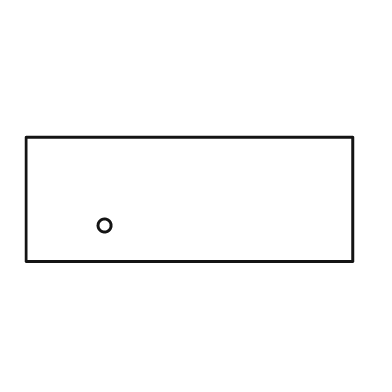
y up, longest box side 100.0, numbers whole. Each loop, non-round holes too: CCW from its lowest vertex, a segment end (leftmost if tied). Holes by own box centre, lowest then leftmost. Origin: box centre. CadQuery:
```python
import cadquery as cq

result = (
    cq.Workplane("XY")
    .moveTo(-50.0, -19.0)
    .lineTo(50.0, -19.0)
    .lineTo(50.0, 19.0)
    .lineTo(-50.0, 19.0)
    .close()
    .moveTo(-26.0, -8.0)
    .circle(2.0)
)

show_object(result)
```